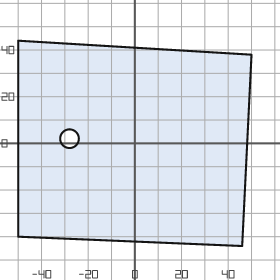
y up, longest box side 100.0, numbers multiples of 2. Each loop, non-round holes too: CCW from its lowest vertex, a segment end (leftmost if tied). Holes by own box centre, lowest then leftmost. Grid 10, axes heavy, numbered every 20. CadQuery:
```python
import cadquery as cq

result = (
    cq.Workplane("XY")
    .moveTo(46.0, -44.0)
    .lineTo(50.0, 38.0)
    .lineTo(-50.0, 44.0)
    .lineTo(-50.0, -40.0)
    .close()
    .moveTo(-28.0, 2.0)
    .circle(4.0)
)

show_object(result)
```